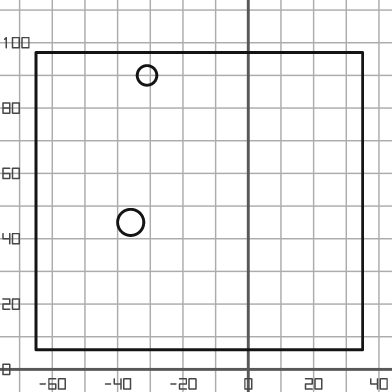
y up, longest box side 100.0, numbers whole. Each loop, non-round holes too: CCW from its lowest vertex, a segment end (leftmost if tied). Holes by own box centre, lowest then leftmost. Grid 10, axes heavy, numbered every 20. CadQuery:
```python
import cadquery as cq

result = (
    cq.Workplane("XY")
    .moveTo(-65.0, 6.0)
    .lineTo(35.0, 6.0)
    .lineTo(35.0, 97.0)
    .lineTo(-65.0, 97.0)
    .close()
    .moveTo(-36.0, 45.0)
    .circle(4.0)
    .moveTo(-31.0, 90.0)
    .circle(3.0)
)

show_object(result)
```